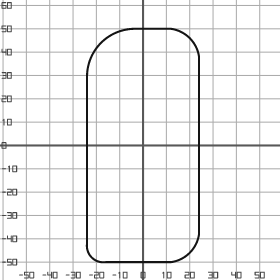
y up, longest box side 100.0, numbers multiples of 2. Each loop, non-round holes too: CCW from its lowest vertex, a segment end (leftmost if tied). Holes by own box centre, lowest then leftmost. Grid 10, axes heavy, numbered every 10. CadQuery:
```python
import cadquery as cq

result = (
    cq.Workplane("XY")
    .moveTo(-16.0, -50.0)
    .lineTo(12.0, -50.0)
    .threePointArc((20.0, -46.0), (24.0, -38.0))
    .lineTo(24.0, 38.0)
    .threePointArc((20.0, 46.0), (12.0, 50.0))
    .lineTo(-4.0, 50.0)
    .threePointArc((-18.0, 44.0), (-24.0, 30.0))
    .lineTo(-24.0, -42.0)
    .threePointArc((-22.0, -48.0), (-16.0, -50.0))
    .close()
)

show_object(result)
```